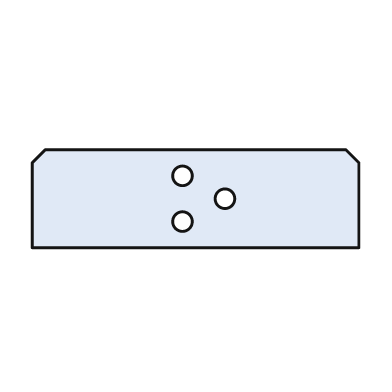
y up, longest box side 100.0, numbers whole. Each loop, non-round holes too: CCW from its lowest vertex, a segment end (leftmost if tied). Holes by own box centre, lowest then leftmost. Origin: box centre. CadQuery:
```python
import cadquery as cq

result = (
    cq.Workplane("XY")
    .moveTo(-50.0, -15.0)
    .lineTo(50.0, -15.0)
    .lineTo(50.0, 11.0)
    .lineTo(46.0, 15.0)
    .lineTo(-46.0, 15.0)
    .lineTo(-50.0, 11.0)
    .close()
    .moveTo(-4.0, -7.0)
    .circle(3.0)
    .moveTo(9.0, 0.0)
    .circle(3.0)
    .moveTo(-4.0, 7.0)
    .circle(3.0)
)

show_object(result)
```